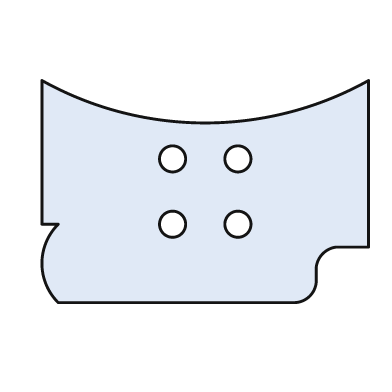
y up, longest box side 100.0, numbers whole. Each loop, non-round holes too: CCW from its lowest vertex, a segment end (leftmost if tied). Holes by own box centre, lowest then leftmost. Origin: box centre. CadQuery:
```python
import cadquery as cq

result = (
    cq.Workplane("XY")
    .moveTo(-45.0, -34.0)
    .lineTo(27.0, -34.0)
    .threePointArc((32.0, -32.0), (34.0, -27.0))
    .lineTo(34.0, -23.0)
    .threePointArc((36.0, -19.0), (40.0, -17.0))
    .lineTo(50.0, -17.0)
    .lineTo(50.0, 34.0)
    .threePointArc((0.0, 21.0), (-50.0, 34.0))
    .lineTo(-50.0, -10.0)
    .lineTo(-45.0, -10.0)
    .threePointArc((-50.0, -22.0), (-45.0, -34.0))
    .close()
    .moveTo(-10.0, -10.0)
    .circle(4.0)
    .moveTo(10.0, -10.0)
    .circle(4.0)
    .moveTo(-10.0, 10.0)
    .circle(4.0)
    .moveTo(10.0, 10.0)
    .circle(4.0)
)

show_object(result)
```